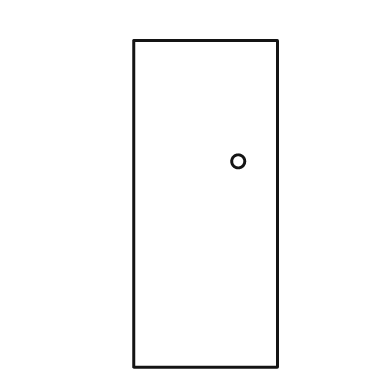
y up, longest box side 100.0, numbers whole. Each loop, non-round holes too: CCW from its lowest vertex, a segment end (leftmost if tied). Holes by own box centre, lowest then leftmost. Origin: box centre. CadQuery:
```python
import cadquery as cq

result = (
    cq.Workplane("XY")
    .moveTo(-22.0, -50.0)
    .lineTo(22.0, -50.0)
    .lineTo(22.0, 50.0)
    .lineTo(-22.0, 50.0)
    .close()
    .moveTo(10.0, 13.0)
    .circle(2.0)
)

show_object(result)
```